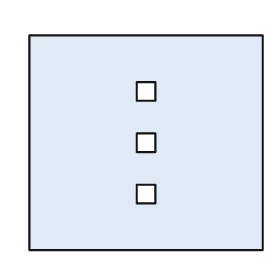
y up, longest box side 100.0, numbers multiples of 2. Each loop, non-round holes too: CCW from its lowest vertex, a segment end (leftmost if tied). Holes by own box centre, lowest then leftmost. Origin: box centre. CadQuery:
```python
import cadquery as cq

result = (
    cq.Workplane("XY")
    .moveTo(-50.0, -46.0)
    .lineTo(50.0, -46.0)
    .lineTo(50.0, 46.0)
    .lineTo(-50.0, 46.0)
    .close()
    .moveTo(-4.0, -26.0)
    .lineTo(4.0, -26.0)
    .lineTo(4.0, -18.0)
    .lineTo(-4.0, -18.0)
    .close()
    .moveTo(-4.0, -4.0)
    .lineTo(4.0, -4.0)
    .lineTo(4.0, 4.0)
    .lineTo(-4.0, 4.0)
    .close()
    .moveTo(-4.0, 18.0)
    .lineTo(4.0, 18.0)
    .lineTo(4.0, 26.0)
    .lineTo(-4.0, 26.0)
    .close()
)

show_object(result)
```